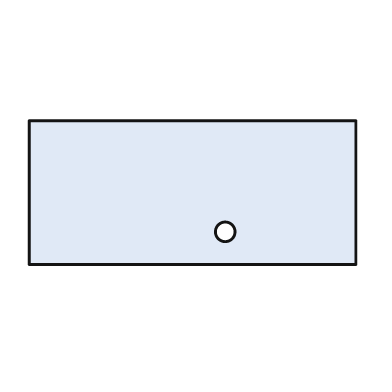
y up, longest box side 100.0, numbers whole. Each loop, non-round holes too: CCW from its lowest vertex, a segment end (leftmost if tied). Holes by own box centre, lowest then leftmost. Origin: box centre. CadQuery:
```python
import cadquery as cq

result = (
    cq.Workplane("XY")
    .moveTo(-50.0, -22.0)
    .lineTo(50.0, -22.0)
    .lineTo(50.0, 22.0)
    .lineTo(-50.0, 22.0)
    .close()
    .moveTo(10.0, -12.0)
    .circle(3.0)
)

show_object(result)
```